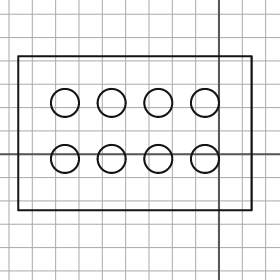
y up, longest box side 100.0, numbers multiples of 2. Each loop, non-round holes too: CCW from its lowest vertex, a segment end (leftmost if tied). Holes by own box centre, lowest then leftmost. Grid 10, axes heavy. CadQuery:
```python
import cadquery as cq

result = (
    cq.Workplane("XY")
    .moveTo(-86.0, -24.0)
    .lineTo(14.0, -24.0)
    .lineTo(14.0, 42.0)
    .lineTo(-86.0, 42.0)
    .close()
    .moveTo(-66.0, -2.0)
    .circle(6.0)
    .moveTo(-46.0, -2.0)
    .circle(6.0)
    .moveTo(-26.0, -2.0)
    .circle(6.0)
    .moveTo(-6.0, -2.0)
    .circle(6.0)
    .moveTo(-66.0, 22.0)
    .circle(6.0)
    .moveTo(-46.0, 22.0)
    .circle(6.0)
    .moveTo(-26.0, 22.0)
    .circle(6.0)
    .moveTo(-6.0, 22.0)
    .circle(6.0)
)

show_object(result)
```